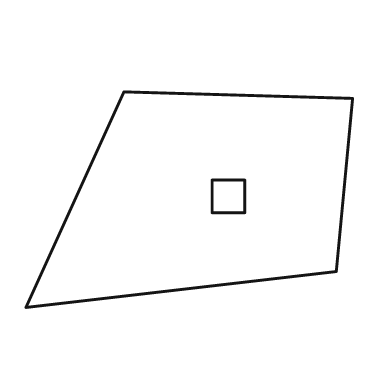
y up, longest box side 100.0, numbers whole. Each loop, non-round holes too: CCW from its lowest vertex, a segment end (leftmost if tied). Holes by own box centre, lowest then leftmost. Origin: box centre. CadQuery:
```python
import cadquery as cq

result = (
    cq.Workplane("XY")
    .moveTo(-50.0, -33.0)
    .lineTo(45.0, -22.0)
    .lineTo(50.0, 31.0)
    .lineTo(-20.0, 33.0)
    .close()
    .moveTo(7.0, -4.0)
    .lineTo(17.0, -4.0)
    .lineTo(17.0, 6.0)
    .lineTo(7.0, 6.0)
    .close()
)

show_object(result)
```